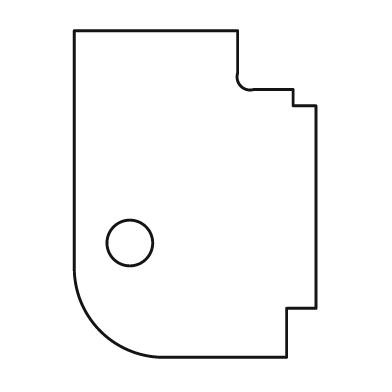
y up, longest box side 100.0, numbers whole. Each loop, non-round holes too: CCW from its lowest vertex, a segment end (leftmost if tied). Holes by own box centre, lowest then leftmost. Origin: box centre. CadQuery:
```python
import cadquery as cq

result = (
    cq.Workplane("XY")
    .moveTo(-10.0, -50.0)
    .lineTo(28.0, -50.0)
    .lineTo(28.0, -35.0)
    .lineTo(37.0, -35.0)
    .lineTo(37.0, 27.0)
    .lineTo(30.0, 27.0)
    .lineTo(30.0, 32.0)
    .lineTo(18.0, 32.0)
    .threePointArc((14.0, 33.0), (13.0, 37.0))
    .lineTo(13.0, 50.0)
    .lineTo(-37.0, 50.0)
    .lineTo(-37.0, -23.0)
    .threePointArc((-29.0, -42.0), (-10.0, -50.0))
    .close()
    .moveTo(-20.0, -15.0)
    .circle(7.0)
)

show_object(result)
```